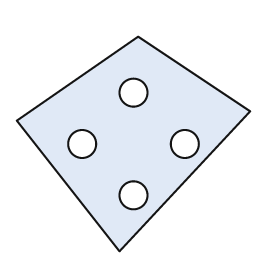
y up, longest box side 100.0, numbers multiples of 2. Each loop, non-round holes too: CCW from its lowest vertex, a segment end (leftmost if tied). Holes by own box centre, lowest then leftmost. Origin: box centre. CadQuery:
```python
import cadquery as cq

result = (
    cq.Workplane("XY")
    .moveTo(-6.0, -46.0)
    .lineTo(50.0, 14.0)
    .lineTo(2.0, 46.0)
    .lineTo(-50.0, 10.0)
    .close()
    .moveTo(0.0, -22.0)
    .circle(6.0)
    .moveTo(-22.0, 0.0)
    .circle(6.0)
    .moveTo(22.0, 0.0)
    .circle(6.0)
    .moveTo(0.0, 22.0)
    .circle(6.0)
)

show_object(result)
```